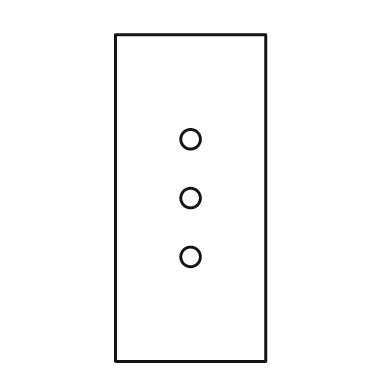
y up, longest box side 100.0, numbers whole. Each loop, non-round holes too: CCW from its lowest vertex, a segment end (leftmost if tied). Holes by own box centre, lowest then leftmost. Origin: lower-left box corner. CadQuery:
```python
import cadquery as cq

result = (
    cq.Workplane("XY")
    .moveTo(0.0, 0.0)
    .lineTo(46.0, 0.0)
    .lineTo(46.0, 100.0)
    .lineTo(0.0, 100.0)
    .close()
    .moveTo(23.0, 32.0)
    .circle(3.0)
    .moveTo(23.0, 50.0)
    .circle(3.0)
    .moveTo(23.0, 68.0)
    .circle(3.0)
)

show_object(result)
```